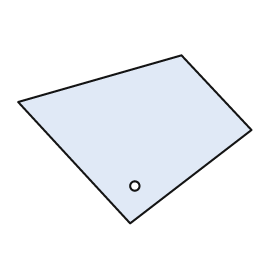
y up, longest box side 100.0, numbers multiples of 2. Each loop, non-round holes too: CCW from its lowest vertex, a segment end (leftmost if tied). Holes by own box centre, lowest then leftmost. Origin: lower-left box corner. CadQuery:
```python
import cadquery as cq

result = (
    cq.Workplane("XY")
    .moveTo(48.0, 0.0)
    .lineTo(100.0, 40.0)
    .lineTo(70.0, 72.0)
    .lineTo(0.0, 52.0)
    .close()
    .moveTo(50.0, 16.0)
    .circle(2.0)
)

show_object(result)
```